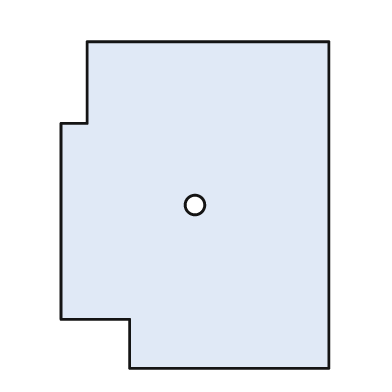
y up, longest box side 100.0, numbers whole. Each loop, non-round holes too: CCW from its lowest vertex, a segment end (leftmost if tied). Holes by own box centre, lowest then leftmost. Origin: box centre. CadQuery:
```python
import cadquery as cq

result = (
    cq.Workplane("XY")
    .moveTo(-20.0, -50.0)
    .lineTo(41.0, -50.0)
    .lineTo(41.0, 50.0)
    .lineTo(-33.0, 50.0)
    .lineTo(-33.0, 25.0)
    .lineTo(-41.0, 25.0)
    .lineTo(-41.0, -35.0)
    .lineTo(-20.0, -35.0)
    .close()
    .moveTo(0.0, 0.0)
    .circle(3.0)
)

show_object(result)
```